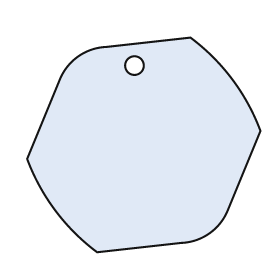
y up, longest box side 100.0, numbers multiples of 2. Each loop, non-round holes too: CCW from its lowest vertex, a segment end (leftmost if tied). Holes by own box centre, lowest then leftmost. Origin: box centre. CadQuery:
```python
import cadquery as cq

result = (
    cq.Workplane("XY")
    .moveTo(-20.0, -46.0)
    .lineTo(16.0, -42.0)
    .threePointArc((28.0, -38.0), (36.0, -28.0))
    .lineTo(50.0, 6.0)
    .threePointArc((38.0, 28.0), (20.0, 46.0))
    .lineTo(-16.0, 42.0)
    .threePointArc((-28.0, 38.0), (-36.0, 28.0))
    .lineTo(-50.0, -6.0)
    .threePointArc((-38.0, -28.0), (-20.0, -46.0))
    .close()
    .moveTo(-4.0, 34.0)
    .circle(4.0)
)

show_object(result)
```